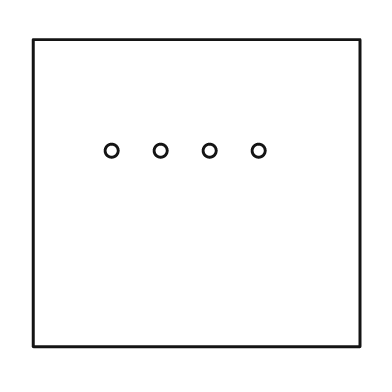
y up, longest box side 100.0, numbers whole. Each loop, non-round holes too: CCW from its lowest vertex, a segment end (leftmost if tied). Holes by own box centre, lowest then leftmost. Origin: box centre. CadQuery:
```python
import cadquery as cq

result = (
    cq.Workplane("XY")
    .moveTo(-50.0, -47.0)
    .lineTo(50.0, -47.0)
    .lineTo(50.0, 47.0)
    .lineTo(-50.0, 47.0)
    .close()
    .moveTo(-26.0, 13.0)
    .circle(2.0)
    .moveTo(-11.0, 13.0)
    .circle(2.0)
    .moveTo(4.0, 13.0)
    .circle(2.0)
    .moveTo(19.0, 13.0)
    .circle(2.0)
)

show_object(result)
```